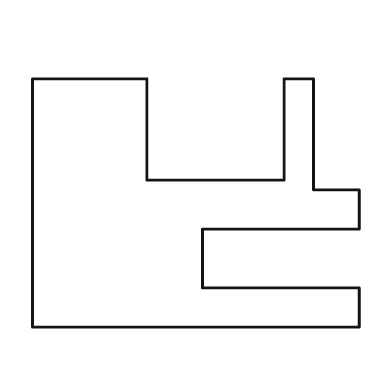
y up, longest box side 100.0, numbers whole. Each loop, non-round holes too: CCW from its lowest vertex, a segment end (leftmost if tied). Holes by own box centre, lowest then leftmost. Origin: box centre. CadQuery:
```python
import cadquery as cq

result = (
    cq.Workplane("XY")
    .moveTo(-50.0, -38.0)
    .lineTo(50.0, -38.0)
    .lineTo(50.0, -26.0)
    .lineTo(2.0, -26.0)
    .lineTo(2.0, -8.0)
    .lineTo(50.0, -8.0)
    .lineTo(50.0, 4.0)
    .lineTo(36.0, 4.0)
    .lineTo(36.0, 38.0)
    .lineTo(27.0, 38.0)
    .lineTo(27.0, 7.0)
    .lineTo(-15.0, 7.0)
    .lineTo(-15.0, 38.0)
    .lineTo(-50.0, 38.0)
    .close()
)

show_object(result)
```